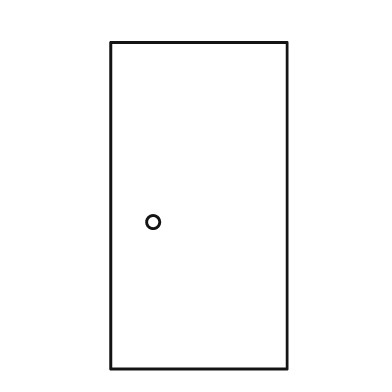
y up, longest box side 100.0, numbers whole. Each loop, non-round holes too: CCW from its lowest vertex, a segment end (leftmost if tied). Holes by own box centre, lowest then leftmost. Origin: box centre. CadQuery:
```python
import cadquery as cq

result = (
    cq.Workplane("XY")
    .moveTo(-27.0, -50.0)
    .lineTo(27.0, -50.0)
    .lineTo(27.0, 50.0)
    .lineTo(-27.0, 50.0)
    .close()
    .moveTo(-14.0, -5.0)
    .circle(2.0)
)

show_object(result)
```